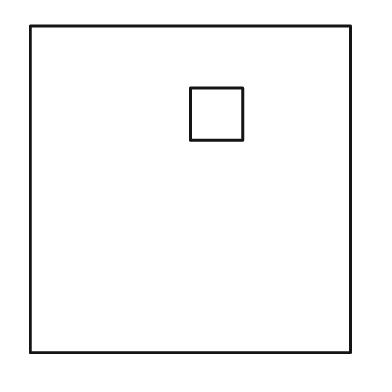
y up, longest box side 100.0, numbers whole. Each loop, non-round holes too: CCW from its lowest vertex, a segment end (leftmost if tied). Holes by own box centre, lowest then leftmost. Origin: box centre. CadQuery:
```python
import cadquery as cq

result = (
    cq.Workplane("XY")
    .moveTo(-49.0, -50.0)
    .lineTo(49.0, -50.0)
    .lineTo(49.0, 50.0)
    .lineTo(-49.0, 50.0)
    .close()
    .moveTo(0.0, 15.0)
    .lineTo(16.0, 15.0)
    .lineTo(16.0, 31.0)
    .lineTo(0.0, 31.0)
    .close()
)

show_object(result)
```